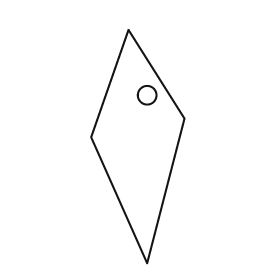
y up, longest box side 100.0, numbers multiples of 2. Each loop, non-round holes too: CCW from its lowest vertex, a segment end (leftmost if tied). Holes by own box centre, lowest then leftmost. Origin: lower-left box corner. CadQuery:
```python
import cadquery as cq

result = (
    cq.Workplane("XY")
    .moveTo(24.0, 0.0)
    .lineTo(40.0, 62.0)
    .lineTo(16.0, 100.0)
    .lineTo(0.0, 54.0)
    .close()
    .moveTo(24.0, 72.0)
    .circle(4.0)
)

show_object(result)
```